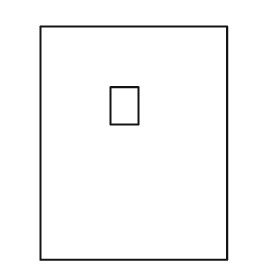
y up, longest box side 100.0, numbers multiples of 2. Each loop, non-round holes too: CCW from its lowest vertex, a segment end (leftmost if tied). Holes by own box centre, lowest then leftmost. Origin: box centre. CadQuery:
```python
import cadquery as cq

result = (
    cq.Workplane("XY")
    .moveTo(-40.0, -50.0)
    .lineTo(40.0, -50.0)
    .lineTo(40.0, 50.0)
    .lineTo(-40.0, 50.0)
    .close()
    .moveTo(-10.0, 8.0)
    .lineTo(2.0, 8.0)
    .lineTo(2.0, 24.0)
    .lineTo(-10.0, 24.0)
    .close()
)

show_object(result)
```